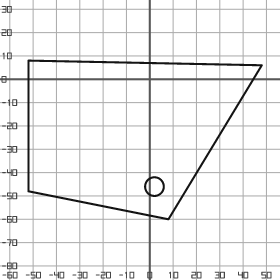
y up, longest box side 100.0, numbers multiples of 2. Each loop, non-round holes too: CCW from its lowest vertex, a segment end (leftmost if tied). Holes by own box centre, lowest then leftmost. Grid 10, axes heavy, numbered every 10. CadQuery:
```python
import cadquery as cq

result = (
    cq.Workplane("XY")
    .moveTo(8.0, -60.0)
    .lineTo(48.0, 6.0)
    .lineTo(-52.0, 8.0)
    .lineTo(-52.0, -48.0)
    .close()
    .moveTo(2.0, -46.0)
    .circle(4.0)
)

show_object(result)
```